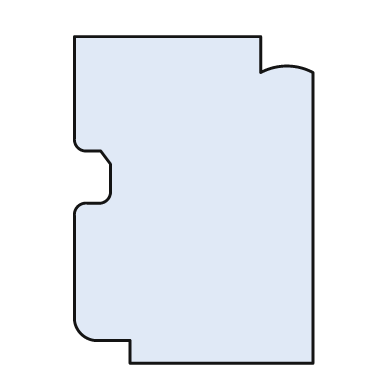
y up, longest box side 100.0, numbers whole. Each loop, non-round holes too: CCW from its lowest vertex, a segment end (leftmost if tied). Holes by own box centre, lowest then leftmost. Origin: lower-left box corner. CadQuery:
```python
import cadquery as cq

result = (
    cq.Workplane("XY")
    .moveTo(17.0, 0.0)
    .lineTo(73.0, 0.0)
    .lineTo(73.0, 89.0)
    .threePointArc((65.0, 91.0), (57.0, 89.0))
    .lineTo(57.0, 100.0)
    .lineTo(0.0, 100.0)
    .lineTo(0.0, 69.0)
    .threePointArc((1.0, 66.0), (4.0, 65.0))
    .lineTo(8.0, 65.0)
    .lineTo(11.0, 61.0)
    .lineTo(11.0, 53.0)
    .threePointArc((10.0, 50.0), (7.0, 49.0))
    .lineTo(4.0, 49.0)
    .threePointArc((1.0, 48.0), (0.0, 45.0))
    .lineTo(0.0, 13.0)
    .threePointArc((2.0, 9.0), (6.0, 7.0))
    .lineTo(17.0, 7.0)
    .close()
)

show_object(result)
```